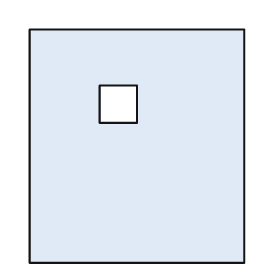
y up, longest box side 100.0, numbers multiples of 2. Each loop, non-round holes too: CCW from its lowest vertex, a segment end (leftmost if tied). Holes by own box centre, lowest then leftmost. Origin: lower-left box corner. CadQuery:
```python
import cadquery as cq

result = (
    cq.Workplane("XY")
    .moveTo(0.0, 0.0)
    .lineTo(92.0, 0.0)
    .lineTo(92.0, 100.0)
    .lineTo(0.0, 100.0)
    .close()
    .moveTo(30.0, 60.0)
    .lineTo(46.0, 60.0)
    .lineTo(46.0, 76.0)
    .lineTo(30.0, 76.0)
    .close()
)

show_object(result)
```